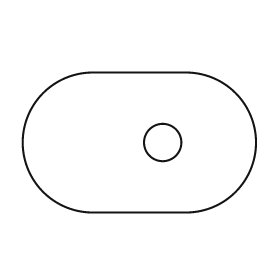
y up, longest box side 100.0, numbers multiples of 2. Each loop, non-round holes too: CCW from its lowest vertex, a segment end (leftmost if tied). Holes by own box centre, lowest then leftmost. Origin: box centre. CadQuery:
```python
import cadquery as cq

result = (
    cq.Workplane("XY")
    .moveTo(-20.0, -30.0)
    .lineTo(20.0, -30.0)
    .threePointArc((50.0, 0.0), (20.0, 30.0))
    .lineTo(-20.0, 30.0)
    .threePointArc((-50.0, 0.0), (-20.0, -30.0))
    .close()
    .moveTo(10.0, 0.0)
    .circle(8.0)
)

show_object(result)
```